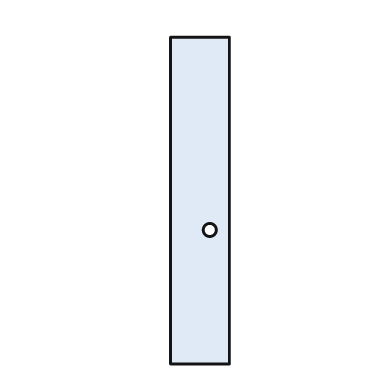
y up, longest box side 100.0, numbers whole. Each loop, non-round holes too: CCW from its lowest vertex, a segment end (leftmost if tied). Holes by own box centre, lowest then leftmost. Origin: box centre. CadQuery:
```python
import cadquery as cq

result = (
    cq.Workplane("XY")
    .moveTo(-9.0, -50.0)
    .lineTo(9.0, -50.0)
    .lineTo(9.0, 50.0)
    .lineTo(-9.0, 50.0)
    .close()
    .moveTo(3.0, -9.0)
    .circle(2.0)
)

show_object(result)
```